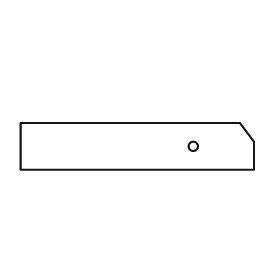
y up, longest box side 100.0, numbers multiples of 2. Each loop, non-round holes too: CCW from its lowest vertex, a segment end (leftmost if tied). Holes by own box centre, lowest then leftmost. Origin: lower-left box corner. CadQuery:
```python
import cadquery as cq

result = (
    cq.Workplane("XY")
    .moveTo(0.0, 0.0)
    .lineTo(100.0, 0.0)
    .lineTo(100.0, 12.0)
    .lineTo(94.0, 20.0)
    .lineTo(0.0, 20.0)
    .close()
    .moveTo(74.0, 10.0)
    .circle(2.0)
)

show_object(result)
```